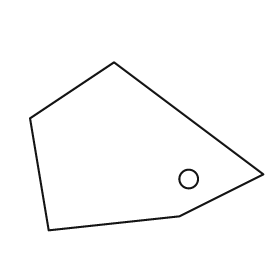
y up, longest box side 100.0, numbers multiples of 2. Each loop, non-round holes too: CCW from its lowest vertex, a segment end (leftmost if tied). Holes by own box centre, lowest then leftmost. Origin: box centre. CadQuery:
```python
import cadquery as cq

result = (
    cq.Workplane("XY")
    .moveTo(-42.0, -36.0)
    .lineTo(14.0, -30.0)
    .lineTo(50.0, -12.0)
    .lineTo(-14.0, 36.0)
    .lineTo(-50.0, 12.0)
    .close()
    .moveTo(18.0, -14.0)
    .circle(4.0)
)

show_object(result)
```